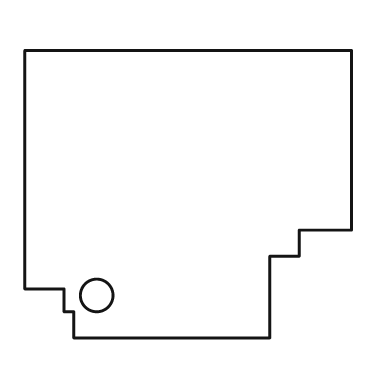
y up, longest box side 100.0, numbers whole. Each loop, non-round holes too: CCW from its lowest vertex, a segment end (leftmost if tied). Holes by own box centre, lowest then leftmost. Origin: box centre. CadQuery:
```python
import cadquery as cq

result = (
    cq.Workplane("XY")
    .moveTo(-35.0, -44.0)
    .lineTo(25.0, -44.0)
    .lineTo(25.0, -19.0)
    .lineTo(34.0, -19.0)
    .lineTo(34.0, -11.0)
    .lineTo(50.0, -11.0)
    .lineTo(50.0, 44.0)
    .lineTo(-50.0, 44.0)
    .lineTo(-50.0, -29.0)
    .lineTo(-38.0, -29.0)
    .lineTo(-38.0, -36.0)
    .lineTo(-35.0, -36.0)
    .close()
    .moveTo(-28.0, -31.0)
    .circle(5.0)
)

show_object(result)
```